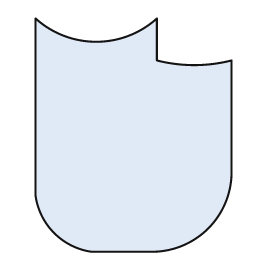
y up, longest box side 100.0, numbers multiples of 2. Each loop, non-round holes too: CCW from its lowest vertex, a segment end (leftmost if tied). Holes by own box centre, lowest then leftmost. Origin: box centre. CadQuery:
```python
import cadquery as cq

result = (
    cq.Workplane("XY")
    .moveTo(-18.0, -50.0)
    .lineTo(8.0, -50.0)
    .threePointArc((32.0, -40.0), (42.0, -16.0))
    .lineTo(42.0, 32.0)
    .threePointArc((26.0, 30.0), (10.0, 32.0))
    .lineTo(10.0, 50.0)
    .threePointArc((-16.0, 40.0), (-42.0, 50.0))
    .lineTo(-42.0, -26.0)
    .threePointArc((-34.0, -42.0), (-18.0, -50.0))
    .close()
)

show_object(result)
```